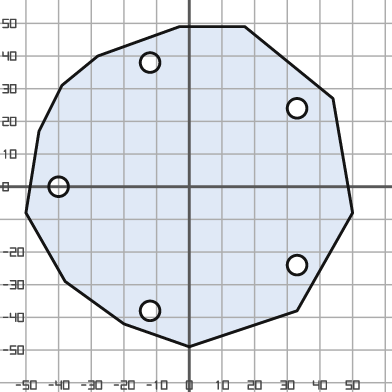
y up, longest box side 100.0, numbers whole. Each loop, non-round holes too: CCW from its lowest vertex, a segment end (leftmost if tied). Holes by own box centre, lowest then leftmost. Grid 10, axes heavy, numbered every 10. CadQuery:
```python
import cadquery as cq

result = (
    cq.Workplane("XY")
    .moveTo(0.0, -49.0)
    .lineTo(33.0, -38.0)
    .lineTo(50.0, -8.0)
    .lineTo(44.0, 27.0)
    .lineTo(17.0, 49.0)
    .lineTo(-3.0, 49.0)
    .lineTo(-28.0, 40.0)
    .lineTo(-39.0, 31.0)
    .lineTo(-46.0, 17.0)
    .lineTo(-50.0, -8.0)
    .lineTo(-38.0, -29.0)
    .lineTo(-20.0, -42.0)
    .close()
    .moveTo(-12.0, -38.0)
    .circle(3.0)
    .moveTo(33.0, -24.0)
    .circle(3.0)
    .moveTo(-40.0, 0.0)
    .circle(3.0)
    .moveTo(33.0, 24.0)
    .circle(3.0)
    .moveTo(-12.0, 38.0)
    .circle(3.0)
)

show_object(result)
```